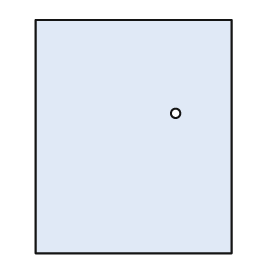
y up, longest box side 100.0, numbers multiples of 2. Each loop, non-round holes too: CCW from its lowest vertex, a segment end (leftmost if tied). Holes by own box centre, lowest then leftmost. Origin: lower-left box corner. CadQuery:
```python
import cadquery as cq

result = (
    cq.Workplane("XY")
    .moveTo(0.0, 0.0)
    .lineTo(84.0, 0.0)
    .lineTo(84.0, 100.0)
    .lineTo(0.0, 100.0)
    .close()
    .moveTo(60.0, 60.0)
    .circle(2.0)
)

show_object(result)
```